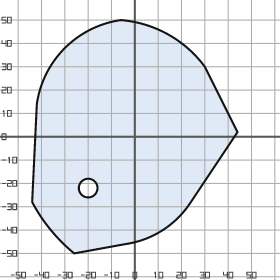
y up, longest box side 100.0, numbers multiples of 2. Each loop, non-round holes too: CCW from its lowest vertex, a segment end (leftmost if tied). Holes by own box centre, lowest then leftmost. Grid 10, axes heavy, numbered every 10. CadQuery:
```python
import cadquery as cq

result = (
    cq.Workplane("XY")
    .moveTo(-26.0, -50.0)
    .lineTo(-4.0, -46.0)
    .threePointArc((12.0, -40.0), (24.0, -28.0))
    .lineTo(44.0, 2.0)
    .lineTo(30.0, 30.0)
    .threePointArc((14.0, 44.0), (-6.0, 50.0))
    .threePointArc((-30.0, 38.0), (-42.0, 14.0))
    .lineTo(-44.0, -28.0)
    .threePointArc((-36.0, -40.0), (-26.0, -50.0))
    .close()
    .moveTo(-20.0, -22.0)
    .circle(4.0)
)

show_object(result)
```